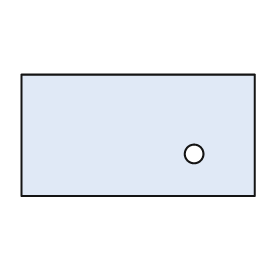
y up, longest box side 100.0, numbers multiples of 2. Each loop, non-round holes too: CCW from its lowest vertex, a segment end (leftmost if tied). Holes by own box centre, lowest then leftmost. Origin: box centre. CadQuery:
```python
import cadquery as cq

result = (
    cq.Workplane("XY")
    .moveTo(-50.0, -26.0)
    .lineTo(50.0, -26.0)
    .lineTo(50.0, 26.0)
    .lineTo(-50.0, 26.0)
    .close()
    .moveTo(24.0, -8.0)
    .circle(4.0)
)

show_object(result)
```